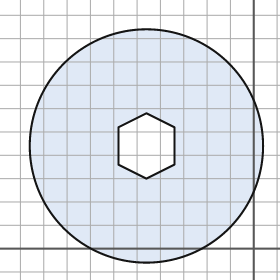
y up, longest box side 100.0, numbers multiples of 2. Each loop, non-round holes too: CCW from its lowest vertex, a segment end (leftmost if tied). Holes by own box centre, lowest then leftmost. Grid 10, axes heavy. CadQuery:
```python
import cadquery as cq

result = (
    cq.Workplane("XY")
    .moveTo(-46.0, 44.0)
    .circle(50.0)
    .moveTo(-46.0, 30.0)
    .lineTo(-34.0, 36.0)
    .lineTo(-34.0, 52.0)
    .lineTo(-46.0, 58.0)
    .lineTo(-58.0, 52.0)
    .lineTo(-58.0, 36.0)
    .close()
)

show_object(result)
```